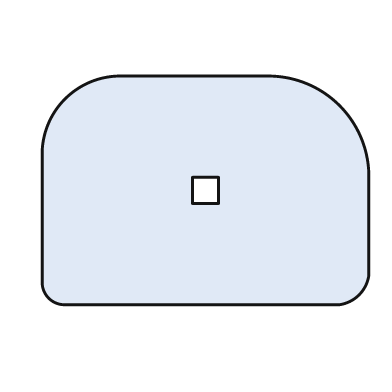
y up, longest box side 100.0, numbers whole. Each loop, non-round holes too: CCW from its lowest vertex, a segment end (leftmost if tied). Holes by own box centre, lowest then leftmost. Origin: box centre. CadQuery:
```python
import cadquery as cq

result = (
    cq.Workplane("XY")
    .moveTo(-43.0, -35.0)
    .lineTo(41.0, -35.0)
    .threePointArc((47.0, -32.0), (50.0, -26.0))
    .lineTo(50.0, 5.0)
    .threePointArc((41.0, 26.0), (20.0, 35.0))
    .lineTo(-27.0, 35.0)
    .threePointArc((-43.0, 28.0), (-50.0, 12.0))
    .lineTo(-50.0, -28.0)
    .threePointArc((-48.0, -33.0), (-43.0, -35.0))
    .close()
    .moveTo(-4.0, -4.0)
    .lineTo(4.0, -4.0)
    .lineTo(4.0, 4.0)
    .lineTo(-4.0, 4.0)
    .close()
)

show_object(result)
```